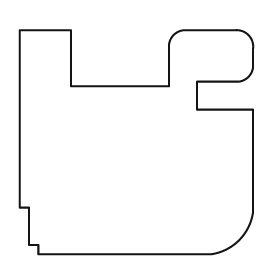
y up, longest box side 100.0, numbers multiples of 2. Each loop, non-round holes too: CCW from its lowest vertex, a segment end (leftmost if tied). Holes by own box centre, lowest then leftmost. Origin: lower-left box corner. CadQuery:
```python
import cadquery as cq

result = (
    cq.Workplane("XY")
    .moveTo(8.0, 0.0)
    .lineTo(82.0, 0.0)
    .threePointArc((94.0, 6.0), (100.0, 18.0))
    .lineTo(100.0, 62.0)
    .lineTo(76.0, 62.0)
    .lineTo(76.0, 74.0)
    .lineTo(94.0, 74.0)
    .threePointArc((98.0, 76.0), (100.0, 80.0))
    .lineTo(100.0, 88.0)
    .threePointArc((98.0, 94.0), (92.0, 96.0))
    .lineTo(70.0, 96.0)
    .threePointArc((66.0, 94.0), (64.0, 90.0))
    .lineTo(64.0, 72.0)
    .lineTo(22.0, 72.0)
    .lineTo(22.0, 96.0)
    .lineTo(0.0, 96.0)
    .lineTo(0.0, 20.0)
    .lineTo(4.0, 20.0)
    .lineTo(4.0, 4.0)
    .lineTo(8.0, 4.0)
    .close()
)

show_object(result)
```